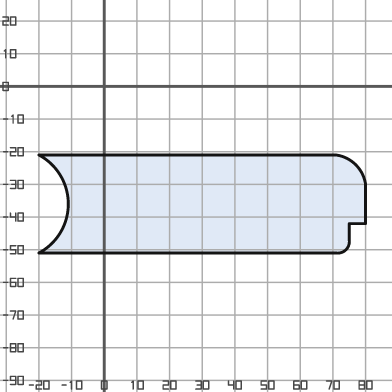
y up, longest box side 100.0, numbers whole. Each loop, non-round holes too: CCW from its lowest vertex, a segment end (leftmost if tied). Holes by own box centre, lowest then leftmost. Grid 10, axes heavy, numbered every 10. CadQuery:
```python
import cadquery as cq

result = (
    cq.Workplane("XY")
    .moveTo(-20.0, -51.0)
    .lineTo(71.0, -51.0)
    .threePointArc((74.0, -50.0), (75.0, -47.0))
    .lineTo(75.0, -42.0)
    .lineTo(80.0, -42.0)
    .lineTo(80.0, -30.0)
    .threePointArc((77.0, -24.0), (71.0, -21.0))
    .lineTo(-20.0, -21.0)
    .threePointArc((-11.0, -36.0), (-20.0, -51.0))
    .close()
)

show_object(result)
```